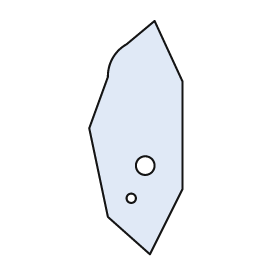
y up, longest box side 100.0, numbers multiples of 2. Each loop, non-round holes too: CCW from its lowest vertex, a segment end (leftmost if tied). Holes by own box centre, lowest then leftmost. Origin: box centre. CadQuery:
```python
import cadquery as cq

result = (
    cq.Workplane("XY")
    .moveTo(6.0, -50.0)
    .lineTo(20.0, -22.0)
    .lineTo(20.0, 24.0)
    .lineTo(8.0, 50.0)
    .lineTo(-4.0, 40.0)
    .threePointArc((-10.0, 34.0), (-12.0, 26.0))
    .lineTo(-20.0, 4.0)
    .lineTo(-12.0, -34.0)
    .close()
    .moveTo(-2.0, -26.0)
    .circle(2.0)
    .moveTo(4.0, -12.0)
    .circle(4.0)
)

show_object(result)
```